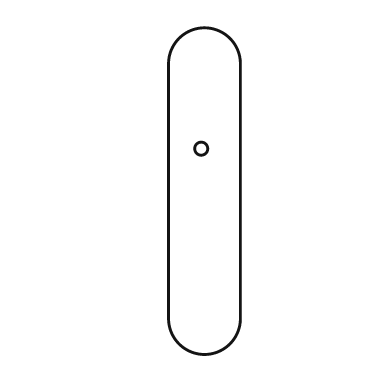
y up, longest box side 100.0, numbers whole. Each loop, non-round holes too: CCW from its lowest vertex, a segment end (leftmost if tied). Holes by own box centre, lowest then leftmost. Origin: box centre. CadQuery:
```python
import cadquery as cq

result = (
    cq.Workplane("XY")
    .moveTo(-11.0, -39.0)
    .threePointArc((0.0, -50.0), (11.0, -39.0))
    .lineTo(11.0, 39.0)
    .threePointArc((0.0, 50.0), (-11.0, 39.0))
    .close()
    .moveTo(-1.0, 13.0)
    .circle(2.0)
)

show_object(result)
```